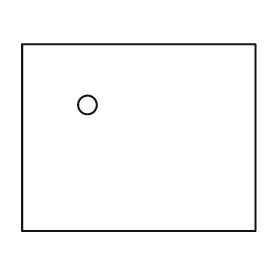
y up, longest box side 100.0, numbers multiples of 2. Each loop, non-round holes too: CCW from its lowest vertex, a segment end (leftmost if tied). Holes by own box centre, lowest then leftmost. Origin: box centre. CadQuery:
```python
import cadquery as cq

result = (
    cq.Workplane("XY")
    .moveTo(-50.0, -40.0)
    .lineTo(50.0, -40.0)
    .lineTo(50.0, 40.0)
    .lineTo(-50.0, 40.0)
    .close()
    .moveTo(-22.0, 14.0)
    .circle(4.0)
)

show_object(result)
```